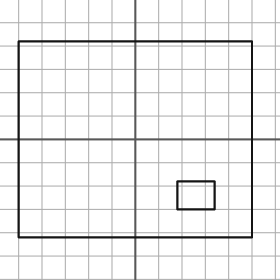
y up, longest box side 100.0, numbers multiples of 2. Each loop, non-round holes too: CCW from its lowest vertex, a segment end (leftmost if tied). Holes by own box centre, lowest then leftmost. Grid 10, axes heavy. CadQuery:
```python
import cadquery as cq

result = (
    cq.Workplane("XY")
    .moveTo(-50.0, -42.0)
    .lineTo(50.0, -42.0)
    .lineTo(50.0, 42.0)
    .lineTo(-50.0, 42.0)
    .close()
    .moveTo(18.0, -30.0)
    .lineTo(34.0, -30.0)
    .lineTo(34.0, -18.0)
    .lineTo(18.0, -18.0)
    .close()
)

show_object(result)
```